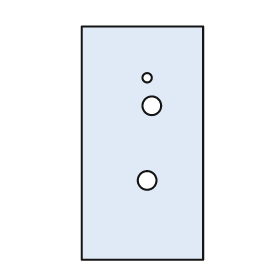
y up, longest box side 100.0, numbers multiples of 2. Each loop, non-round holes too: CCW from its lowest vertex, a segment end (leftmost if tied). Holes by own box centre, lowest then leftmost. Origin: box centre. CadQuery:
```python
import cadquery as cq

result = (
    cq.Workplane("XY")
    .moveTo(-26.0, -50.0)
    .lineTo(26.0, -50.0)
    .lineTo(26.0, 50.0)
    .lineTo(-26.0, 50.0)
    .close()
    .moveTo(2.0, -16.0)
    .circle(4.0)
    .moveTo(4.0, 16.0)
    .circle(4.0)
    .moveTo(2.0, 28.0)
    .circle(2.0)
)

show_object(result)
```